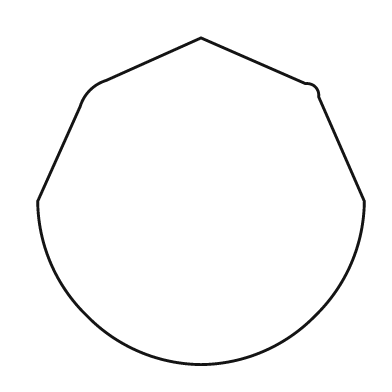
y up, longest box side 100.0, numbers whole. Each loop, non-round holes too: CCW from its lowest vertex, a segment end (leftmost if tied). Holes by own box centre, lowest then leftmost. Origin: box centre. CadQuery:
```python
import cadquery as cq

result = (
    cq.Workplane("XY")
    .moveTo(0.0, -50.0)
    .threePointArc((19.0, -46.0), (35.0, -35.0))
    .threePointArc((46.0, -19.0), (50.0, 0.0))
    .lineTo(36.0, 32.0)
    .threePointArc((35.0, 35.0), (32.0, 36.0))
    .lineTo(0.0, 50.0)
    .lineTo(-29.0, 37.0)
    .threePointArc((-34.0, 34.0), (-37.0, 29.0))
    .lineTo(-50.0, 0.0)
    .threePointArc((-46.0, -19.0), (-35.0, -35.0))
    .threePointArc((-19.0, -46.0), (0.0, -50.0))
    .close()
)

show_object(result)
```